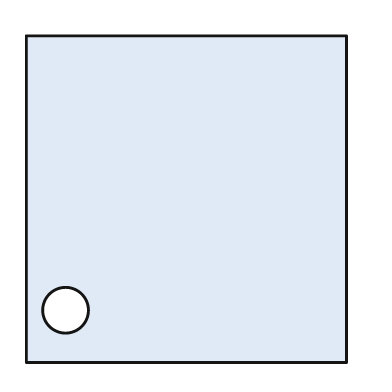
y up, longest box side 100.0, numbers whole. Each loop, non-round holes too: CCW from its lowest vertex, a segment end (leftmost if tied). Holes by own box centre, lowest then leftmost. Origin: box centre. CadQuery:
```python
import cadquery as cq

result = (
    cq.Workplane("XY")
    .moveTo(-49.0, -50.0)
    .lineTo(49.0, -50.0)
    .lineTo(49.0, 50.0)
    .lineTo(-49.0, 50.0)
    .close()
    .moveTo(-37.0, -34.0)
    .circle(7.0)
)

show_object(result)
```